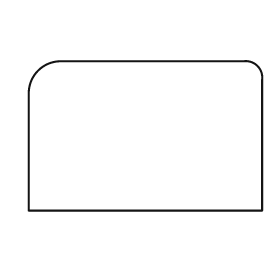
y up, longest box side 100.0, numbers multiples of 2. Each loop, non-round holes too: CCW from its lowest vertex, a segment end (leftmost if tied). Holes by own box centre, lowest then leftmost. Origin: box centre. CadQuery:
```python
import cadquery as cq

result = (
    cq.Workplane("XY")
    .moveTo(-50.0, -32.0)
    .lineTo(50.0, -32.0)
    .lineTo(50.0, 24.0)
    .threePointArc((48.0, 30.0), (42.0, 32.0))
    .lineTo(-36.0, 32.0)
    .threePointArc((-46.0, 28.0), (-50.0, 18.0))
    .close()
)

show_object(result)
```